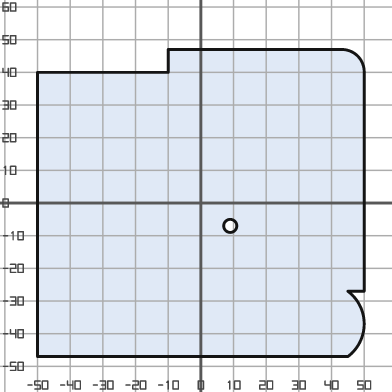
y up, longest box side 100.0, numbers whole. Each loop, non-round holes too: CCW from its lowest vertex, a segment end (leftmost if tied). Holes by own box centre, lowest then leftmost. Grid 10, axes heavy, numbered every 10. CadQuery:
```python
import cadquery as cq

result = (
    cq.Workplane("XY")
    .moveTo(-50.0, -47.0)
    .lineTo(45.0, -47.0)
    .threePointArc((50.0, -37.0), (45.0, -27.0))
    .lineTo(50.0, -27.0)
    .lineTo(50.0, 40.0)
    .threePointArc((48.0, 45.0), (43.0, 47.0))
    .lineTo(-10.0, 47.0)
    .lineTo(-10.0, 40.0)
    .lineTo(-50.0, 40.0)
    .close()
    .moveTo(9.0, -7.0)
    .circle(2.0)
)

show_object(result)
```